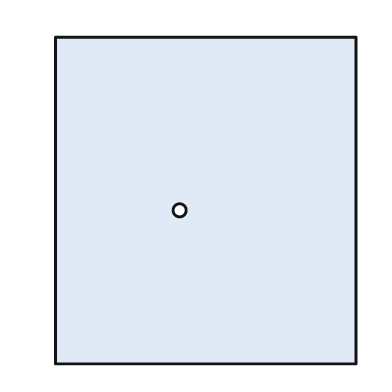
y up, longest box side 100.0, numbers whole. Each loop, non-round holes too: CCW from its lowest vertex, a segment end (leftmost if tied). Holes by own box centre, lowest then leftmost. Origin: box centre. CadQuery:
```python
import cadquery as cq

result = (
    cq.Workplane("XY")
    .moveTo(-46.0, -50.0)
    .lineTo(46.0, -50.0)
    .lineTo(46.0, 50.0)
    .lineTo(-46.0, 50.0)
    .close()
    .moveTo(-8.0, -3.0)
    .circle(2.0)
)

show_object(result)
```